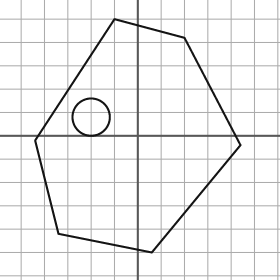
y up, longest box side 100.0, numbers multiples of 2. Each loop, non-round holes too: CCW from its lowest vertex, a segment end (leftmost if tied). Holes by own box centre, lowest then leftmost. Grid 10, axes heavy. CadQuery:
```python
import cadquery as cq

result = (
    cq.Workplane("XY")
    .moveTo(6.0, -50.0)
    .lineTo(44.0, -4.0)
    .lineTo(20.0, 42.0)
    .lineTo(-10.0, 50.0)
    .lineTo(-44.0, -2.0)
    .lineTo(-34.0, -42.0)
    .close()
    .moveTo(-20.0, 8.0)
    .circle(8.0)
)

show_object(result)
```